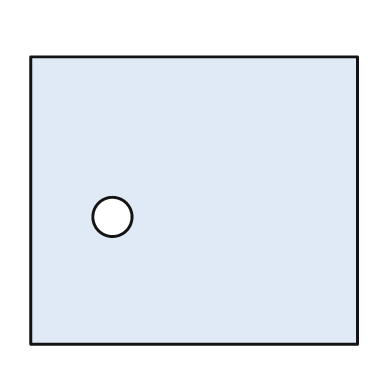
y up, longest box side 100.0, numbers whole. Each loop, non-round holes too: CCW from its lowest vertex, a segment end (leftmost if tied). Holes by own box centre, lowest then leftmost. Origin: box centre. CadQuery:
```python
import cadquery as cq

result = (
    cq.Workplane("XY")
    .moveTo(-50.0, -44.0)
    .lineTo(50.0, -44.0)
    .lineTo(50.0, 44.0)
    .lineTo(-50.0, 44.0)
    .close()
    .moveTo(-25.0, -5.0)
    .circle(6.0)
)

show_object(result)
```